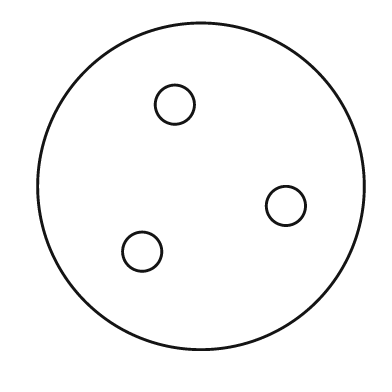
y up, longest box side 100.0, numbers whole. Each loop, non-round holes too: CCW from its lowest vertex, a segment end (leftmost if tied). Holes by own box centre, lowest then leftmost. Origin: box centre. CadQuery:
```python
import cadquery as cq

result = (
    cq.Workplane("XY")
    .moveTo(0.0, 0.0)
    .circle(50.0)
    .moveTo(-18.0, -20.0)
    .circle(6.0)
    .moveTo(26.0, -6.0)
    .circle(6.0)
    .moveTo(-8.0, 25.0)
    .circle(6.0)
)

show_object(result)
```